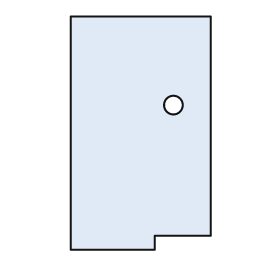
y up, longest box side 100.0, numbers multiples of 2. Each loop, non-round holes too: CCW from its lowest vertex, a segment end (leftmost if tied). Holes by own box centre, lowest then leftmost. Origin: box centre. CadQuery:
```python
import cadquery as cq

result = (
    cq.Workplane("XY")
    .moveTo(-30.0, -50.0)
    .lineTo(6.0, -50.0)
    .lineTo(6.0, -44.0)
    .lineTo(30.0, -44.0)
    .lineTo(30.0, 50.0)
    .lineTo(-30.0, 50.0)
    .close()
    .moveTo(14.0, 12.0)
    .circle(4.0)
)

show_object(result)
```